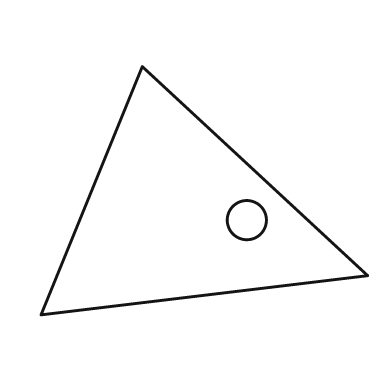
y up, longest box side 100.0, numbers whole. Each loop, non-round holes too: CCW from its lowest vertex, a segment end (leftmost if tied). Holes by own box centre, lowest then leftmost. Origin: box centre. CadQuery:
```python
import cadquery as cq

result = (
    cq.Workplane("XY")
    .moveTo(-50.0, -38.0)
    .lineTo(50.0, -26.0)
    .lineTo(-19.0, 38.0)
    .close()
    .moveTo(13.0, -9.0)
    .circle(6.0)
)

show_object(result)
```